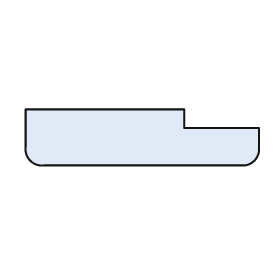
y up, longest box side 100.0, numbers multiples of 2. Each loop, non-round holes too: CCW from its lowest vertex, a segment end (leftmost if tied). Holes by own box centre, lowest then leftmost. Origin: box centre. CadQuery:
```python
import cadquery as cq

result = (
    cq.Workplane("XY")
    .moveTo(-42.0, -12.0)
    .lineTo(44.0, -12.0)
    .threePointArc((48.0, -10.0), (50.0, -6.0))
    .lineTo(50.0, 4.0)
    .lineTo(18.0, 4.0)
    .lineTo(18.0, 12.0)
    .lineTo(-50.0, 12.0)
    .lineTo(-50.0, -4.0)
    .threePointArc((-48.0, -10.0), (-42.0, -12.0))
    .close()
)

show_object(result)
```